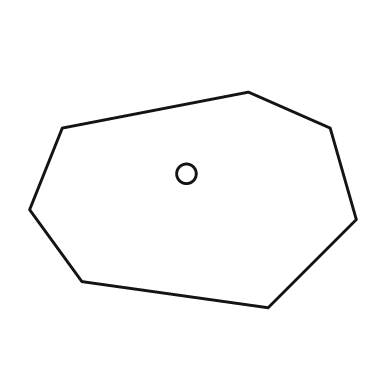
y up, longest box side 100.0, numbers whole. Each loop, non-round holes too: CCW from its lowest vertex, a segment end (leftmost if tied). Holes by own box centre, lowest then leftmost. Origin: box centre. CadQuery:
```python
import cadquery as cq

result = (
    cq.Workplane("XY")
    .moveTo(23.0, -33.0)
    .lineTo(50.0, -6.0)
    .lineTo(42.0, 22.0)
    .lineTo(17.0, 33.0)
    .lineTo(-40.0, 22.0)
    .lineTo(-50.0, -3.0)
    .lineTo(-34.0, -25.0)
    .close()
    .moveTo(-2.0, 8.0)
    .circle(3.0)
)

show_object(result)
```